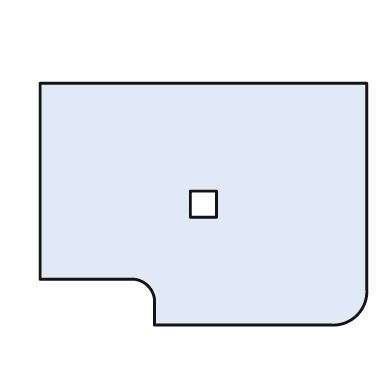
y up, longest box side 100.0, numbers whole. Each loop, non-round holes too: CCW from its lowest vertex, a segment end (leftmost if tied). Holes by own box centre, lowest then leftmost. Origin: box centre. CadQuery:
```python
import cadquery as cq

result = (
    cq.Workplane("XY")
    .moveTo(-15.0, -37.0)
    .lineTo(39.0, -37.0)
    .threePointArc((47.0, -34.0), (50.0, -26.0))
    .lineTo(50.0, 37.0)
    .lineTo(-50.0, 37.0)
    .lineTo(-50.0, -23.0)
    .lineTo(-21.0, -23.0)
    .threePointArc((-17.0, -25.0), (-15.0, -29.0))
    .close()
    .moveTo(-4.0, -4.0)
    .lineTo(4.0, -4.0)
    .lineTo(4.0, 4.0)
    .lineTo(-4.0, 4.0)
    .close()
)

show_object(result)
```